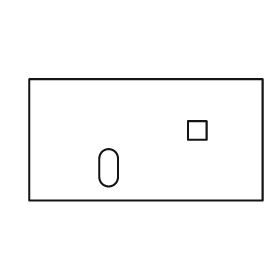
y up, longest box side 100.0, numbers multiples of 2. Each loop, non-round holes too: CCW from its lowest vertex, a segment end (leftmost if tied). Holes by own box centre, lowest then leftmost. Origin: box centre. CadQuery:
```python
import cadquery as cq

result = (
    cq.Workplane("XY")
    .moveTo(-50.0, -26.0)
    .lineTo(50.0, -26.0)
    .lineTo(50.0, 26.0)
    .lineTo(-50.0, 26.0)
    .close()
    .moveTo(-20.0, -16.0)
    .threePointArc((-16.0, -20.0), (-12.0, -16.0))
    .lineTo(-12.0, -8.0)
    .threePointArc((-16.0, -4.0), (-20.0, -8.0))
    .close()
    .moveTo(18.0, 0.0)
    .lineTo(26.0, 0.0)
    .lineTo(26.0, 8.0)
    .lineTo(18.0, 8.0)
    .close()
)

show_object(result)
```